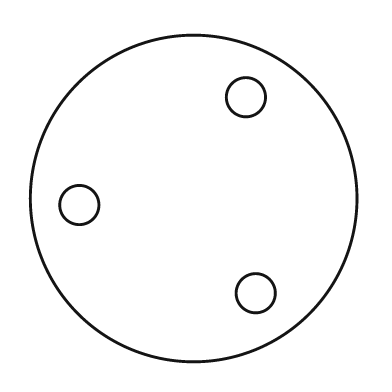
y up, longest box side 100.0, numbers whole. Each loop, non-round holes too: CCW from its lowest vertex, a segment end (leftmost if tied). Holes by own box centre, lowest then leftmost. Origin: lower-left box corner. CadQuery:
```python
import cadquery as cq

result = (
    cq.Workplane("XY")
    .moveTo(50.0, 50.0)
    .circle(50.0)
    .moveTo(69.0, 21.0)
    .circle(6.0)
    .moveTo(15.0, 48.0)
    .circle(6.0)
    .moveTo(66.0, 81.0)
    .circle(6.0)
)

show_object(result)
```